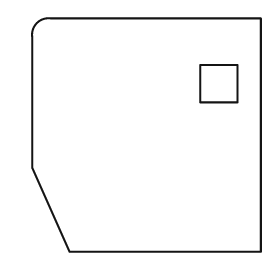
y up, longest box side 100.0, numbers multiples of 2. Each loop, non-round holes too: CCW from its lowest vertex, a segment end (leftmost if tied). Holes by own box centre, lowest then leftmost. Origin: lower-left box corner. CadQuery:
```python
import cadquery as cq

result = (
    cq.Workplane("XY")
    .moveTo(16.0, 0.0)
    .lineTo(98.0, 0.0)
    .lineTo(98.0, 100.0)
    .lineTo(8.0, 100.0)
    .threePointArc((2.0, 98.0), (0.0, 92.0))
    .lineTo(0.0, 36.0)
    .close()
    .moveTo(72.0, 64.0)
    .lineTo(88.0, 64.0)
    .lineTo(88.0, 80.0)
    .lineTo(72.0, 80.0)
    .close()
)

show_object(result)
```